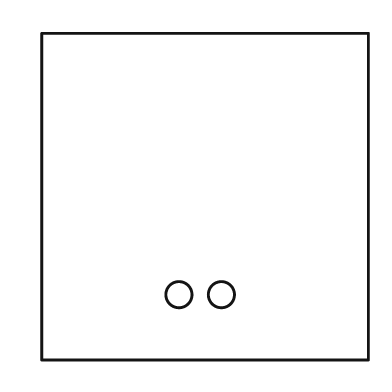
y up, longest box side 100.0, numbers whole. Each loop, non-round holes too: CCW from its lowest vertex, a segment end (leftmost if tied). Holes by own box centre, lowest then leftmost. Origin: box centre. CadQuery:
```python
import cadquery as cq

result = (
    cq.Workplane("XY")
    .moveTo(-50.0, -50.0)
    .lineTo(50.0, -50.0)
    .lineTo(50.0, 50.0)
    .lineTo(-50.0, 50.0)
    .close()
    .moveTo(-8.0, -30.0)
    .circle(4.0)
    .moveTo(5.0, -30.0)
    .circle(4.0)
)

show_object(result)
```